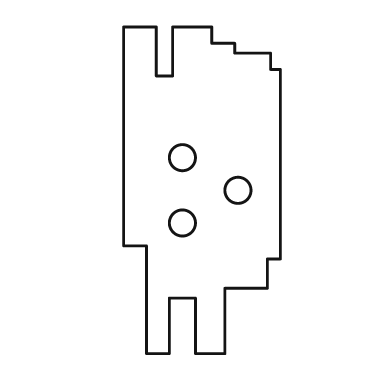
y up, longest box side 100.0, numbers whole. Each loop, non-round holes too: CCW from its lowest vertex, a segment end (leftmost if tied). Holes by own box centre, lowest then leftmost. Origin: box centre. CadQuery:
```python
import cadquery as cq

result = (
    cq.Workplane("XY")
    .moveTo(-17.0, -50.0)
    .lineTo(-10.0, -50.0)
    .lineTo(-10.0, -33.0)
    .lineTo(-2.0, -33.0)
    .lineTo(-2.0, -50.0)
    .lineTo(7.0, -50.0)
    .lineTo(7.0, -30.0)
    .lineTo(20.0, -30.0)
    .lineTo(20.0, -21.0)
    .lineTo(24.0, -21.0)
    .lineTo(24.0, 37.0)
    .lineTo(21.0, 37.0)
    .lineTo(21.0, 42.0)
    .lineTo(10.0, 42.0)
    .lineTo(10.0, 45.0)
    .lineTo(3.0, 45.0)
    .lineTo(3.0, 50.0)
    .lineTo(-9.0, 50.0)
    .lineTo(-9.0, 35.0)
    .lineTo(-14.0, 35.0)
    .lineTo(-14.0, 50.0)
    .lineTo(-24.0, 50.0)
    .lineTo(-24.0, -17.0)
    .lineTo(-17.0, -17.0)
    .close()
    .moveTo(-6.0, -10.0)
    .circle(4.0)
    .moveTo(11.0, 0.0)
    .circle(4.0)
    .moveTo(-6.0, 10.0)
    .circle(4.0)
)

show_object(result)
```